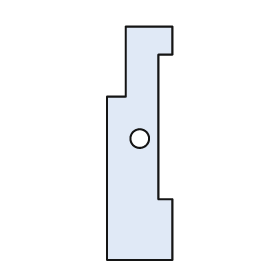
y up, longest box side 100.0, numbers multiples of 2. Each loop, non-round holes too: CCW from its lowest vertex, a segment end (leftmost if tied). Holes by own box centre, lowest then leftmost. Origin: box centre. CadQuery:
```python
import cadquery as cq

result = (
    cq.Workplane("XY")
    .moveTo(-14.0, -50.0)
    .lineTo(14.0, -50.0)
    .lineTo(14.0, -24.0)
    .lineTo(8.0, -24.0)
    .lineTo(8.0, 38.0)
    .lineTo(14.0, 38.0)
    .lineTo(14.0, 50.0)
    .lineTo(-6.0, 50.0)
    .lineTo(-6.0, 20.0)
    .lineTo(-14.0, 20.0)
    .close()
    .moveTo(0.0, 2.0)
    .circle(4.0)
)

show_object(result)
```